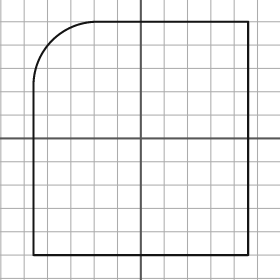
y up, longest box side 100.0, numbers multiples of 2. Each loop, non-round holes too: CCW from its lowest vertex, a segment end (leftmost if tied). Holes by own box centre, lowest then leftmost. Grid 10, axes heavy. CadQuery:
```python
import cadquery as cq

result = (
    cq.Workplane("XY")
    .moveTo(-46.0, -50.0)
    .lineTo(46.0, -50.0)
    .lineTo(46.0, 50.0)
    .lineTo(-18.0, 50.0)
    .threePointArc((-38.0, 42.0), (-46.0, 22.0))
    .close()
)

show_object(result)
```